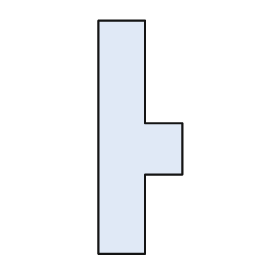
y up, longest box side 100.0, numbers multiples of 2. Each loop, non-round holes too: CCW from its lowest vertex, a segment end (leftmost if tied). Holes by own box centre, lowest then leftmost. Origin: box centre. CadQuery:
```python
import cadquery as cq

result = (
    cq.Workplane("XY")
    .moveTo(-18.0, -50.0)
    .lineTo(2.0, -50.0)
    .lineTo(2.0, -16.0)
    .lineTo(18.0, -16.0)
    .lineTo(18.0, 6.0)
    .lineTo(2.0, 6.0)
    .lineTo(2.0, 50.0)
    .lineTo(-18.0, 50.0)
    .close()
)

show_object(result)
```